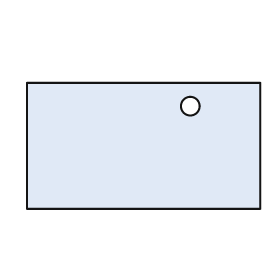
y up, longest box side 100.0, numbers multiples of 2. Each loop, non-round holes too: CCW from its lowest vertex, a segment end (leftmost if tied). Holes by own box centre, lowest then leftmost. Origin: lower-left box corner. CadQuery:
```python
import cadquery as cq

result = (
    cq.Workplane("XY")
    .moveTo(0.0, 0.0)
    .lineTo(100.0, 0.0)
    .lineTo(100.0, 54.0)
    .lineTo(0.0, 54.0)
    .close()
    .moveTo(70.0, 44.0)
    .circle(4.0)
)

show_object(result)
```